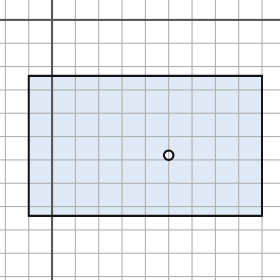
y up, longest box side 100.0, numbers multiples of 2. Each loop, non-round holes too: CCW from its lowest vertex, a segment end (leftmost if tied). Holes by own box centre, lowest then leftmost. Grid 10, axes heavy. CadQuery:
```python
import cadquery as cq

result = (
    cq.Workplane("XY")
    .moveTo(-10.0, -84.0)
    .lineTo(90.0, -84.0)
    .lineTo(90.0, -24.0)
    .lineTo(-10.0, -24.0)
    .close()
    .moveTo(50.0, -58.0)
    .circle(2.0)
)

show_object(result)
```